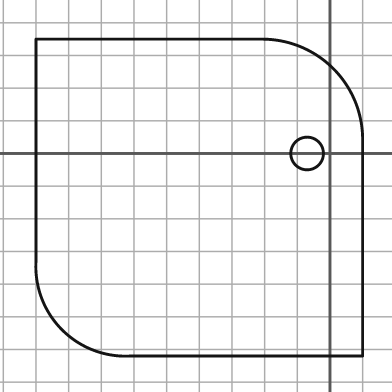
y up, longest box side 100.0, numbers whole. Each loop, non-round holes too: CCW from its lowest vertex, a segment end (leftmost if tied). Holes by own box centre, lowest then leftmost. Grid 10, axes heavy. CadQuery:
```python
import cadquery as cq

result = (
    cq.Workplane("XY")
    .moveTo(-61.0, -62.0)
    .lineTo(10.0, -62.0)
    .lineTo(10.0, 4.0)
    .threePointArc((1.0, 26.0), (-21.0, 35.0))
    .lineTo(-90.0, 35.0)
    .lineTo(-90.0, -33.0)
    .threePointArc((-82.0, -54.0), (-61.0, -62.0))
    .close()
    .moveTo(-7.0, 0.0)
    .circle(5.0)
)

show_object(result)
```